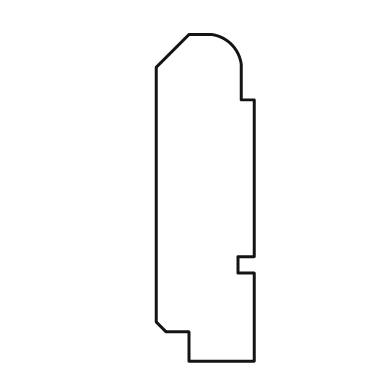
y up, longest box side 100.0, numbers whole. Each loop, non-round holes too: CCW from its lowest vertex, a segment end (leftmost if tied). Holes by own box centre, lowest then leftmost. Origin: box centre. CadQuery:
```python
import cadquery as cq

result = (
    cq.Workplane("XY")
    .moveTo(-5.0, -50.0)
    .lineTo(15.0, -50.0)
    .lineTo(15.0, -23.0)
    .lineTo(10.0, -23.0)
    .lineTo(10.0, -18.0)
    .lineTo(15.0, -18.0)
    .lineTo(15.0, 30.0)
    .lineTo(11.0, 30.0)
    .lineTo(11.0, 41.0)
    .threePointArc((8.0, 47.0), (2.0, 50.0))
    .lineTo(-5.0, 50.0)
    .lineTo(-15.0, 40.0)
    .lineTo(-15.0, -38.0)
    .lineTo(-12.0, -41.0)
    .lineTo(-5.0, -41.0)
    .close()
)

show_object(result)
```